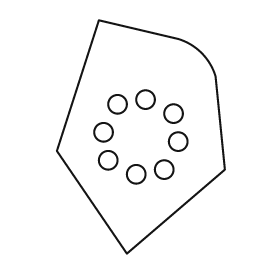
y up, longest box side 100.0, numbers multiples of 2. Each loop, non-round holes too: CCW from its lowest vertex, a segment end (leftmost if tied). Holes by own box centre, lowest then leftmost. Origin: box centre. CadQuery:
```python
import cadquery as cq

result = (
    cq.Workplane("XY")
    .moveTo(-6.0, -50.0)
    .lineTo(36.0, -14.0)
    .lineTo(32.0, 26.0)
    .threePointArc((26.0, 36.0), (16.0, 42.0))
    .lineTo(-18.0, 50.0)
    .lineTo(-36.0, -6.0)
    .close()
    .moveTo(-2.0, -16.0)
    .circle(4.0)
    .moveTo(10.0, -14.0)
    .circle(4.0)
    .moveTo(-14.0, -10.0)
    .circle(4.0)
    .moveTo(16.0, -2.0)
    .circle(4.0)
    .moveTo(-16.0, 2.0)
    .circle(4.0)
    .moveTo(14.0, 10.0)
    .circle(4.0)
    .moveTo(-10.0, 14.0)
    .circle(4.0)
    .moveTo(2.0, 16.0)
    .circle(4.0)
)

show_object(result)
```